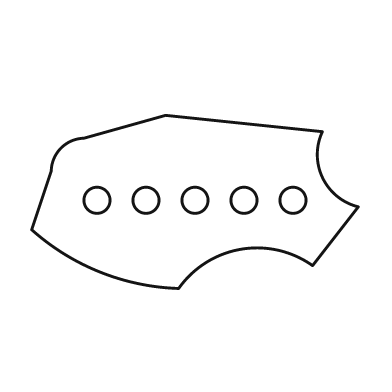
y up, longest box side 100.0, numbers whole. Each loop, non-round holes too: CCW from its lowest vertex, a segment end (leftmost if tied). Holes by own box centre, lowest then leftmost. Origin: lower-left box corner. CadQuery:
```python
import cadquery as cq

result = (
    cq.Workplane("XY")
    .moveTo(45.0, 0.0)
    .threePointArc((64.0, 12.0), (86.0, 7.0))
    .lineTo(100.0, 25.0)
    .threePointArc((89.0, 34.0), (89.0, 48.0))
    .lineTo(41.0, 53.0)
    .lineTo(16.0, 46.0)
    .threePointArc((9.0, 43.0), (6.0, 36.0))
    .lineTo(0.0, 18.0)
    .threePointArc((21.0, 5.0), (45.0, 0.0))
    .close()
    .moveTo(20.0, 27.0)
    .circle(4.0)
    .moveTo(35.0, 27.0)
    .circle(4.0)
    .moveTo(50.0, 27.0)
    .circle(4.0)
    .moveTo(65.0, 27.0)
    .circle(4.0)
    .moveTo(80.0, 27.0)
    .circle(4.0)
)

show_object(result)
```